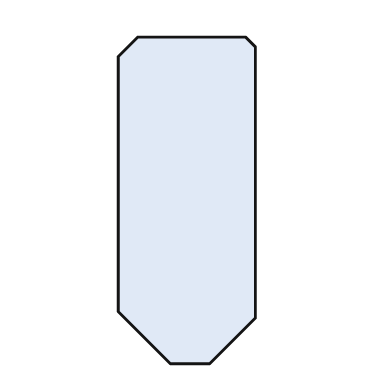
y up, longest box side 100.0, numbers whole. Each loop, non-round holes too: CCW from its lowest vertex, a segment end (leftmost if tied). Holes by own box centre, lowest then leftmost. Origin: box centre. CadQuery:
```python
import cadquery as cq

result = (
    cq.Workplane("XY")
    .moveTo(-5.0, -50.0)
    .lineTo(7.0, -50.0)
    .lineTo(21.0, -36.0)
    .lineTo(21.0, 47.0)
    .lineTo(18.0, 50.0)
    .lineTo(-15.0, 50.0)
    .lineTo(-21.0, 44.0)
    .lineTo(-21.0, -34.0)
    .close()
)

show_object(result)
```